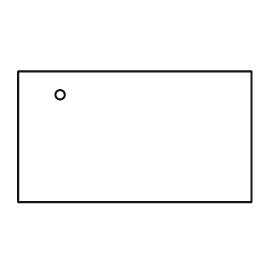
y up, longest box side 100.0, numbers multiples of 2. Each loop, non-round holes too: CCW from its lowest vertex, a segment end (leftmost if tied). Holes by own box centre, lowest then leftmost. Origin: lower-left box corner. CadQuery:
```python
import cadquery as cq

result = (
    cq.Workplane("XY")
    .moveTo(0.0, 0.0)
    .lineTo(100.0, 0.0)
    .lineTo(100.0, 56.0)
    .lineTo(0.0, 56.0)
    .close()
    .moveTo(18.0, 46.0)
    .circle(2.0)
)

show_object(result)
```